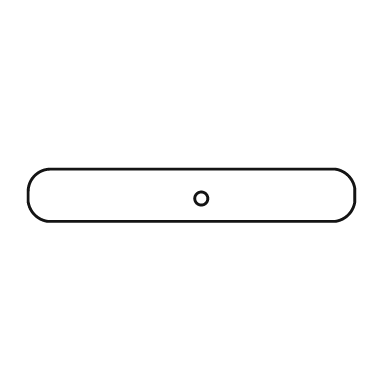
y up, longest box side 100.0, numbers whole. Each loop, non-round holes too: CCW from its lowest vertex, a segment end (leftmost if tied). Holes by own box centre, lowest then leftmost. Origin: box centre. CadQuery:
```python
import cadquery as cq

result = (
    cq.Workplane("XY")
    .moveTo(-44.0, -8.0)
    .lineTo(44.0, -8.0)
    .threePointArc((48.0, -6.0), (50.0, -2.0))
    .lineTo(50.0, 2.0)
    .threePointArc((48.0, 6.0), (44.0, 8.0))
    .lineTo(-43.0, 8.0)
    .threePointArc((-48.0, 6.0), (-50.0, 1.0))
    .lineTo(-50.0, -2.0)
    .threePointArc((-48.0, -6.0), (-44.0, -8.0))
    .close()
    .moveTo(3.0, -1.0)
    .circle(2.0)
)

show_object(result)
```